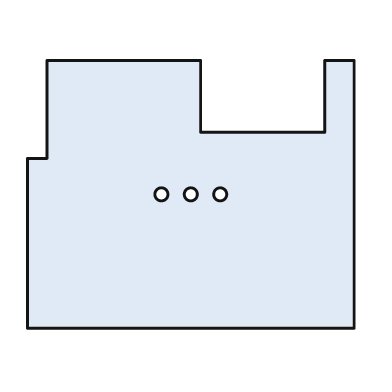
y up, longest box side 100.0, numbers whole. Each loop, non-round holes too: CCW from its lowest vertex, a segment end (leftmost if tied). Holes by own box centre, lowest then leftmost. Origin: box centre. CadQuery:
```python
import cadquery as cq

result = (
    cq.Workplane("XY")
    .moveTo(-50.0, -41.0)
    .lineTo(50.0, -41.0)
    .lineTo(50.0, 41.0)
    .lineTo(41.0, 41.0)
    .lineTo(41.0, 19.0)
    .lineTo(3.0, 19.0)
    .lineTo(3.0, 41.0)
    .lineTo(-44.0, 41.0)
    .lineTo(-44.0, 11.0)
    .lineTo(-50.0, 11.0)
    .close()
    .moveTo(-9.0, 0.0)
    .circle(2.0)
    .moveTo(0.0, 0.0)
    .circle(2.0)
    .moveTo(9.0, 0.0)
    .circle(2.0)
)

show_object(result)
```